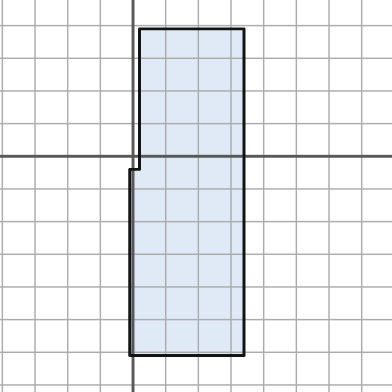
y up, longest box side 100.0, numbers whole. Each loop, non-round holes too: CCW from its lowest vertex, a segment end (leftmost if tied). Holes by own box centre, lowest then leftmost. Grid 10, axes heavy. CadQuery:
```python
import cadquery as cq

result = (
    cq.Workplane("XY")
    .moveTo(-1.0, -61.0)
    .lineTo(34.0, -61.0)
    .lineTo(34.0, 39.0)
    .lineTo(2.0, 39.0)
    .lineTo(2.0, -4.0)
    .lineTo(-1.0, -4.0)
    .close()
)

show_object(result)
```